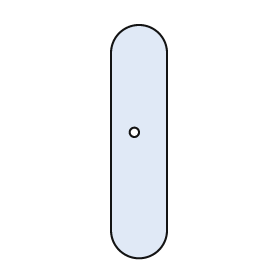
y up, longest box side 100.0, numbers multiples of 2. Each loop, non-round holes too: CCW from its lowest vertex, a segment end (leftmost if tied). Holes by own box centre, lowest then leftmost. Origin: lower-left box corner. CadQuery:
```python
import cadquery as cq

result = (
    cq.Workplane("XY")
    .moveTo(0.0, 12.0)
    .threePointArc((12.0, 0.0), (24.0, 12.0))
    .lineTo(24.0, 88.0)
    .threePointArc((12.0, 100.0), (0.0, 88.0))
    .close()
    .moveTo(10.0, 54.0)
    .circle(2.0)
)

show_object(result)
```